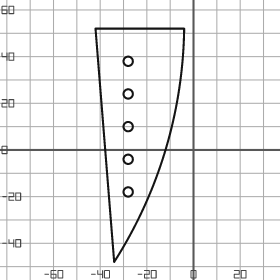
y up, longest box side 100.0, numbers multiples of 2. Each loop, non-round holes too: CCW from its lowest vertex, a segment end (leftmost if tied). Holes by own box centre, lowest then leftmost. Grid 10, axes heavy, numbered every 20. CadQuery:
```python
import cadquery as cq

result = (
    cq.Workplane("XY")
    .moveTo(-34.0, -48.0)
    .threePointArc((-12.0, 0.0), (-4.0, 52.0))
    .lineTo(-42.0, 52.0)
    .close()
    .moveTo(-28.0, -18.0)
    .circle(2.0)
    .moveTo(-28.0, -4.0)
    .circle(2.0)
    .moveTo(-28.0, 10.0)
    .circle(2.0)
    .moveTo(-28.0, 24.0)
    .circle(2.0)
    .moveTo(-28.0, 38.0)
    .circle(2.0)
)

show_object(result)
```